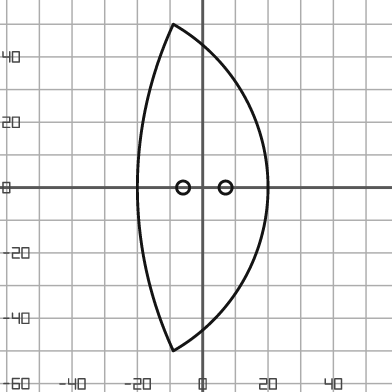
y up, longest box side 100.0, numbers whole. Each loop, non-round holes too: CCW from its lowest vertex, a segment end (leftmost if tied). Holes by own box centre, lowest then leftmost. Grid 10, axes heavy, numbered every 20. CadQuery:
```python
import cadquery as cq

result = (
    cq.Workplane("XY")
    .moveTo(-9.0, -50.0)
    .threePointArc((20.0, 0.0), (-9.0, 50.0))
    .threePointArc((-20.0, 0.0), (-9.0, -50.0))
    .close()
    .moveTo(-6.0, 0.0)
    .circle(2.0)
    .moveTo(7.0, 0.0)
    .circle(2.0)
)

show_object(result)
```